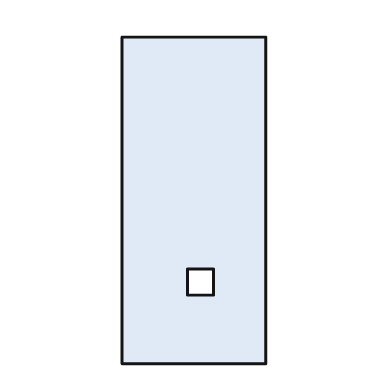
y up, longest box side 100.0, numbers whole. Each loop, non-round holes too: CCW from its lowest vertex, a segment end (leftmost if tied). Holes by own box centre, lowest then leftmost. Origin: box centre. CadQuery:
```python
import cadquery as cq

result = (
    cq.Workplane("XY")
    .moveTo(-22.0, -50.0)
    .lineTo(22.0, -50.0)
    .lineTo(22.0, 50.0)
    .lineTo(-22.0, 50.0)
    .close()
    .moveTo(-2.0, -29.0)
    .lineTo(6.0, -29.0)
    .lineTo(6.0, -21.0)
    .lineTo(-2.0, -21.0)
    .close()
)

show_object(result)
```